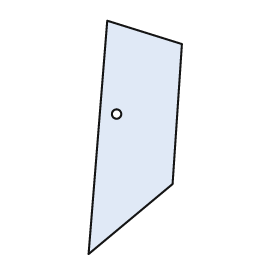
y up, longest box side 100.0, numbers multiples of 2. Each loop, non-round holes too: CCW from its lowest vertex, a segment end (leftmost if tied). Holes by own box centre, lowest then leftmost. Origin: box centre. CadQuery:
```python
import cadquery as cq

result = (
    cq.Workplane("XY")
    .moveTo(-20.0, -50.0)
    .lineTo(16.0, -20.0)
    .lineTo(20.0, 40.0)
    .lineTo(-12.0, 50.0)
    .close()
    .moveTo(-8.0, 10.0)
    .circle(2.0)
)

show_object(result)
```